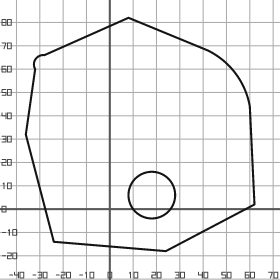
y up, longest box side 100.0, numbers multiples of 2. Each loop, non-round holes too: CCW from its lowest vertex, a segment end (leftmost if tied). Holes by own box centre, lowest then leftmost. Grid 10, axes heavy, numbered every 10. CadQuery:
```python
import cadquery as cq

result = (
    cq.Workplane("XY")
    .moveTo(24.0, -18.0)
    .lineTo(62.0, 2.0)
    .lineTo(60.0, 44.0)
    .threePointArc((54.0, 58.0), (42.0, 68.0))
    .lineTo(8.0, 82.0)
    .lineTo(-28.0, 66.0)
    .threePointArc((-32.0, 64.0), (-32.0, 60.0))
    .lineTo(-36.0, 32.0)
    .lineTo(-24.0, -14.0)
    .close()
    .moveTo(18.0, 6.0)
    .circle(10.0)
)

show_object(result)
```